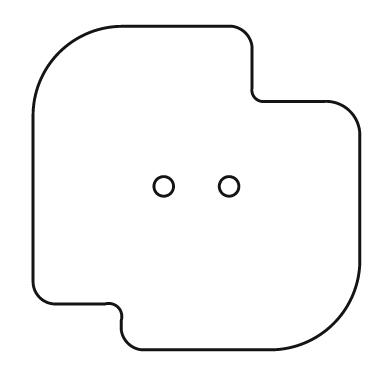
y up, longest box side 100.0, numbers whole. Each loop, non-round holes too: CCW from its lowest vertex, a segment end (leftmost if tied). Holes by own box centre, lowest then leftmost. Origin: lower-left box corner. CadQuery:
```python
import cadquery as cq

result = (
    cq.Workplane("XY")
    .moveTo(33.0, 0.0)
    .lineTo(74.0, 0.0)
    .threePointArc((92.0, 8.0), (100.0, 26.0))
    .lineTo(100.0, 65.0)
    .threePointArc((97.0, 73.0), (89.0, 76.0))
    .lineTo(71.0, 76.0)
    .threePointArc((68.0, 77.0), (67.0, 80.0))
    .lineTo(67.0, 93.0)
    .threePointArc((65.0, 97.0), (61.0, 99.0))
    .lineTo(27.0, 99.0)
    .threePointArc((8.0, 91.0), (0.0, 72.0))
    .lineTo(0.0, 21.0)
    .threePointArc((2.0, 16.0), (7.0, 14.0))
    .lineTo(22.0, 14.0)
    .threePointArc((26.0, 13.0), (27.0, 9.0))
    .lineTo(27.0, 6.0)
    .threePointArc((29.0, 2.0), (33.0, 0.0))
    .close()
    .moveTo(40.0, 50.0)
    .circle(3.0)
    .moveTo(60.0, 50.0)
    .circle(3.0)
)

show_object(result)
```